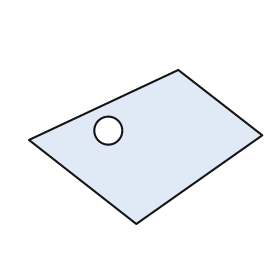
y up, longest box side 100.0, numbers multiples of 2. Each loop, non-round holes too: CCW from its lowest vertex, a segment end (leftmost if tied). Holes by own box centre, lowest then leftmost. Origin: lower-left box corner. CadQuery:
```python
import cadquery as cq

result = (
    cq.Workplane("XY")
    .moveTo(46.0, 0.0)
    .lineTo(100.0, 38.0)
    .lineTo(64.0, 66.0)
    .lineTo(0.0, 36.0)
    .close()
    .moveTo(34.0, 40.0)
    .circle(6.0)
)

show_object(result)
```